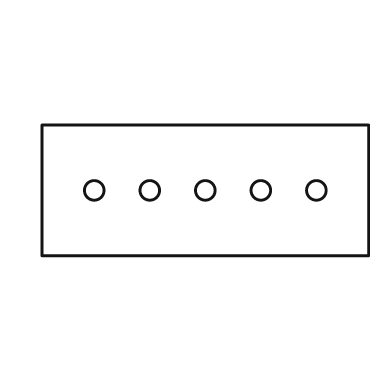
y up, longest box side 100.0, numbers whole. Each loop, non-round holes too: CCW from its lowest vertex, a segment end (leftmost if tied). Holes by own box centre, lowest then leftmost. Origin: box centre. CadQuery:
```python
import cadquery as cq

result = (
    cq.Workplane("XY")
    .moveTo(-50.0, -20.0)
    .lineTo(50.0, -20.0)
    .lineTo(50.0, 20.0)
    .lineTo(-50.0, 20.0)
    .close()
    .moveTo(-34.0, 0.0)
    .circle(3.0)
    .moveTo(-17.0, 0.0)
    .circle(3.0)
    .moveTo(0.0, 0.0)
    .circle(3.0)
    .moveTo(17.0, 0.0)
    .circle(3.0)
    .moveTo(34.0, 0.0)
    .circle(3.0)
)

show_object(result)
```